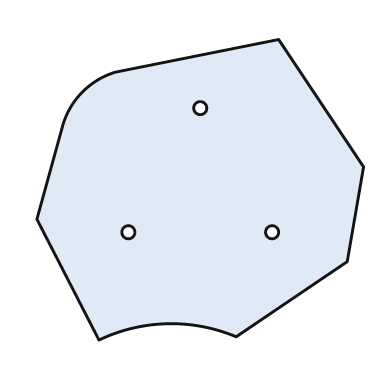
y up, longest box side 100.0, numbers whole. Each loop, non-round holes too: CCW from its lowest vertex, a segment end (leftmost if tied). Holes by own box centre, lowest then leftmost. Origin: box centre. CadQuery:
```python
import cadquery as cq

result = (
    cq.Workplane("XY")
    .moveTo(-31.0, -46.0)
    .threePointArc((-10.0, -41.0), (11.0, -45.0))
    .lineTo(45.0, -22.0)
    .lineTo(50.0, 7.0)
    .lineTo(24.0, 46.0)
    .lineTo(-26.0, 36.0)
    .threePointArc((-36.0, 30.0), (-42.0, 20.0))
    .lineTo(-50.0, -9.0)
    .close()
    .moveTo(-22.0, -13.0)
    .circle(2.0)
    .moveTo(22.0, -13.0)
    .circle(2.0)
    .moveTo(0.0, 25.0)
    .circle(2.0)
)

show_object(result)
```